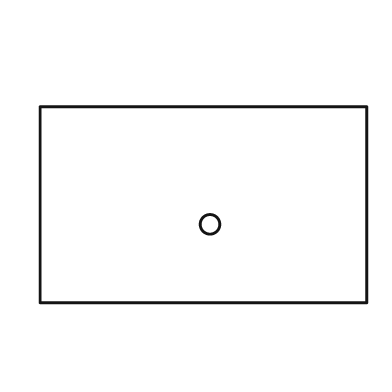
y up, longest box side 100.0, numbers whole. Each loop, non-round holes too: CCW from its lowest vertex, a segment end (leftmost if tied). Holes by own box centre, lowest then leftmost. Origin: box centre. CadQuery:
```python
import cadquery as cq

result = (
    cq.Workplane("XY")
    .moveTo(-50.0, -30.0)
    .lineTo(50.0, -30.0)
    .lineTo(50.0, 30.0)
    .lineTo(-50.0, 30.0)
    .close()
    .moveTo(2.0, -6.0)
    .circle(3.0)
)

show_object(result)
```